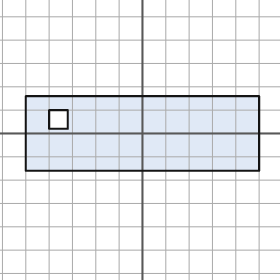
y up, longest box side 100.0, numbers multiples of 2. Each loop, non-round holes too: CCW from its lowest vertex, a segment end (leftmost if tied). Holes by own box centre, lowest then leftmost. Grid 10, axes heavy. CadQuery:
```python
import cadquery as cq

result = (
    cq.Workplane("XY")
    .moveTo(-50.0, -16.0)
    .lineTo(50.0, -16.0)
    .lineTo(50.0, 16.0)
    .lineTo(-50.0, 16.0)
    .close()
    .moveTo(-40.0, 2.0)
    .lineTo(-32.0, 2.0)
    .lineTo(-32.0, 10.0)
    .lineTo(-40.0, 10.0)
    .close()
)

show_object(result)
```